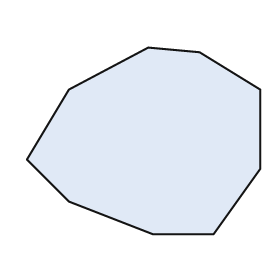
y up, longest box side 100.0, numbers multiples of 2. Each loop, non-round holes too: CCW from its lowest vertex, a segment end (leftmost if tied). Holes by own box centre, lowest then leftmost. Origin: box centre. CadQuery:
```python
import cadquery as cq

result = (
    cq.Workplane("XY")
    .moveTo(4.0, -40.0)
    .lineTo(30.0, -40.0)
    .lineTo(50.0, -12.0)
    .lineTo(50.0, 22.0)
    .lineTo(24.0, 38.0)
    .lineTo(2.0, 40.0)
    .lineTo(-32.0, 22.0)
    .lineTo(-50.0, -8.0)
    .lineTo(-32.0, -26.0)
    .close()
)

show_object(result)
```